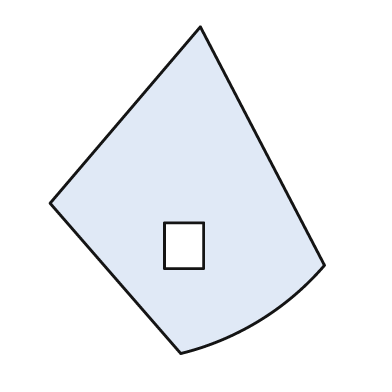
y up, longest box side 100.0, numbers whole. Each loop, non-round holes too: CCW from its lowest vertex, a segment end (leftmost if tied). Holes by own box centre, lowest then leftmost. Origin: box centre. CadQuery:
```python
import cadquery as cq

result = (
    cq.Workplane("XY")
    .moveTo(-2.0, -50.0)
    .threePointArc((22.0, -40.0), (42.0, -23.0))
    .lineTo(4.0, 50.0)
    .lineTo(-42.0, -4.0)
    .close()
    .moveTo(-7.0, -24.0)
    .lineTo(5.0, -24.0)
    .lineTo(5.0, -10.0)
    .lineTo(-7.0, -10.0)
    .close()
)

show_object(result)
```